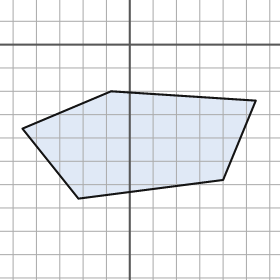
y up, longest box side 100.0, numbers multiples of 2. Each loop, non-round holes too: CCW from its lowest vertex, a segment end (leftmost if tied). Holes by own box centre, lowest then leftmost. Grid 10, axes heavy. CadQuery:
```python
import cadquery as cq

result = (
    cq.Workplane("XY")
    .moveTo(-22.0, -66.0)
    .lineTo(40.0, -58.0)
    .lineTo(54.0, -24.0)
    .lineTo(-8.0, -20.0)
    .lineTo(-46.0, -36.0)
    .close()
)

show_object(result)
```